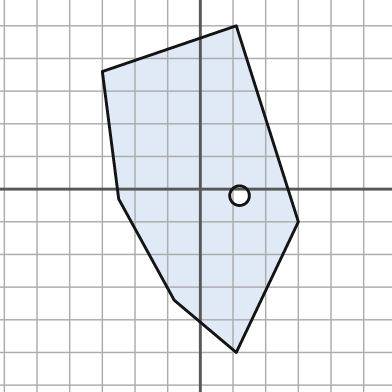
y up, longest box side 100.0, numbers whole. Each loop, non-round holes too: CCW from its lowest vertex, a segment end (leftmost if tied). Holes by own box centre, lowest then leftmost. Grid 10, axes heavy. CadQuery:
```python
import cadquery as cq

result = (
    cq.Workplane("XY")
    .moveTo(11.0, -50.0)
    .lineTo(30.0, -10.0)
    .lineTo(11.0, 50.0)
    .lineTo(-30.0, 36.0)
    .lineTo(-25.0, -3.0)
    .lineTo(-8.0, -34.0)
    .close()
    .moveTo(12.0, -2.0)
    .circle(3.0)
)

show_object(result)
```